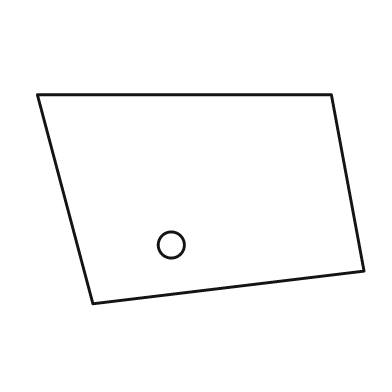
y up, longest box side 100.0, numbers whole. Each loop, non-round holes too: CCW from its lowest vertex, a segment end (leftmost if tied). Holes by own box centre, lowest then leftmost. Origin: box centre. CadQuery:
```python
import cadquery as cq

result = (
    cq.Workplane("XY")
    .moveTo(-33.0, -32.0)
    .lineTo(50.0, -22.0)
    .lineTo(40.0, 32.0)
    .lineTo(-50.0, 32.0)
    .close()
    .moveTo(-9.0, -14.0)
    .circle(4.0)
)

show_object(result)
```